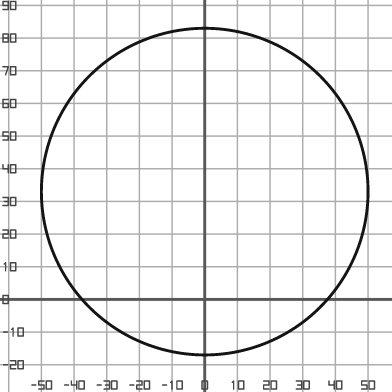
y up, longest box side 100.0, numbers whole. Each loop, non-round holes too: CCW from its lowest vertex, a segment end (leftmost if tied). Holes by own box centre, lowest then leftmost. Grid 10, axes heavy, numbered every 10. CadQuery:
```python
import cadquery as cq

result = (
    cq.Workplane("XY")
    .moveTo(0.0, 33.0)
    .circle(50.0)
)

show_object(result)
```